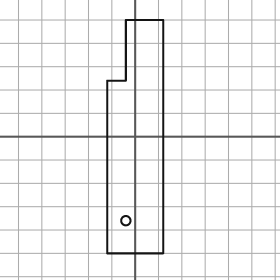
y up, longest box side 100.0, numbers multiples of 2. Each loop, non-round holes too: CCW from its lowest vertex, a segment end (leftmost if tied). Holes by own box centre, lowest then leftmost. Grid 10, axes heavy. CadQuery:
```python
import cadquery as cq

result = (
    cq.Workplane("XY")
    .moveTo(-12.0, -50.0)
    .lineTo(12.0, -50.0)
    .lineTo(12.0, 50.0)
    .lineTo(-4.0, 50.0)
    .lineTo(-4.0, 24.0)
    .lineTo(-12.0, 24.0)
    .close()
    .moveTo(-4.0, -36.0)
    .circle(2.0)
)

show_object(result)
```